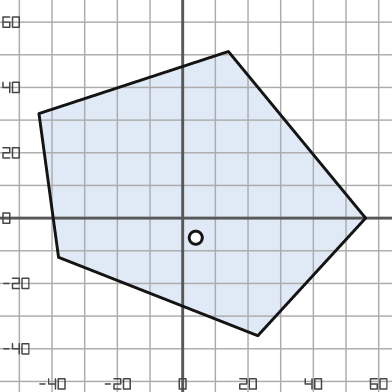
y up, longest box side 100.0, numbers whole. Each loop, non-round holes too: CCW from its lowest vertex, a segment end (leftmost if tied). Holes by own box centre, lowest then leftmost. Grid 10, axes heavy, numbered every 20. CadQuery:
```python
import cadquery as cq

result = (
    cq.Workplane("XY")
    .moveTo(23.0, -36.0)
    .lineTo(56.0, 0.0)
    .lineTo(14.0, 51.0)
    .lineTo(-44.0, 32.0)
    .lineTo(-38.0, -12.0)
    .close()
    .moveTo(4.0, -6.0)
    .circle(2.0)
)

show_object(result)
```